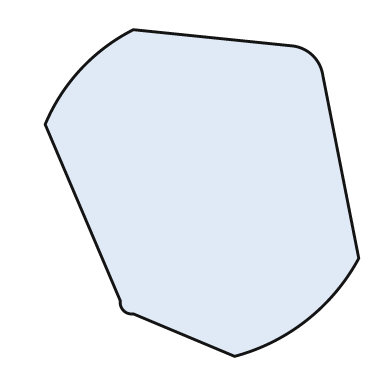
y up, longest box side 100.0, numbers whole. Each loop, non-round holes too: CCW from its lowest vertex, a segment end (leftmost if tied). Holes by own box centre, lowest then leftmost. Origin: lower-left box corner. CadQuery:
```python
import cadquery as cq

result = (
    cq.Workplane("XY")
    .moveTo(58.0, 0.0)
    .threePointArc((80.0, 11.0), (96.0, 30.0))
    .lineTo(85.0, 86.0)
    .threePointArc((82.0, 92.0), (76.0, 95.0))
    .lineTo(27.0, 100.0)
    .threePointArc((11.0, 88.0), (0.0, 71.0))
    .lineTo(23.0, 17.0)
    .threePointArc((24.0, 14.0), (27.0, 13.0))
    .close()
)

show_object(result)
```